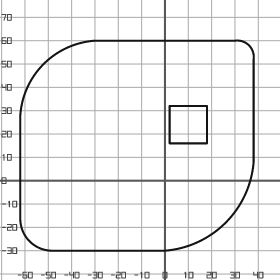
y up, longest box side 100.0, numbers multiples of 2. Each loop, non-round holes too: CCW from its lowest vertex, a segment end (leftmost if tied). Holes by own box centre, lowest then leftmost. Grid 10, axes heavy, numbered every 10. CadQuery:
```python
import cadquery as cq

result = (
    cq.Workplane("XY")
    .moveTo(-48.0, -30.0)
    .lineTo(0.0, -30.0)
    .threePointArc((26.0, -18.0), (38.0, 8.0))
    .lineTo(38.0, 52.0)
    .threePointArc((36.0, 58.0), (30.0, 60.0))
    .lineTo(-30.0, 60.0)
    .threePointArc((-52.0, 50.0), (-62.0, 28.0))
    .lineTo(-62.0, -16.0)
    .threePointArc((-58.0, -26.0), (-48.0, -30.0))
    .close()
    .moveTo(2.0, 16.0)
    .lineTo(18.0, 16.0)
    .lineTo(18.0, 32.0)
    .lineTo(2.0, 32.0)
    .close()
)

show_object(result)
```